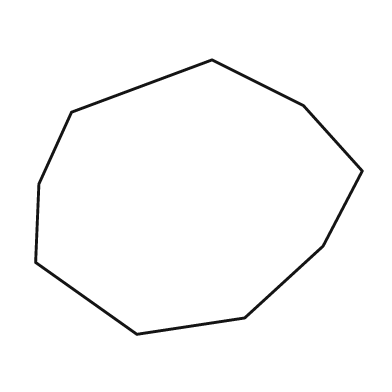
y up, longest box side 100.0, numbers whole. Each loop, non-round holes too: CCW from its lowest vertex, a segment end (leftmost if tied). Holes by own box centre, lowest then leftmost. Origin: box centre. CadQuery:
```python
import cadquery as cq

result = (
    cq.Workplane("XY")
    .moveTo(-19.0, -42.0)
    .lineTo(14.0, -37.0)
    .lineTo(38.0, -15.0)
    .lineTo(50.0, 8.0)
    .lineTo(32.0, 28.0)
    .lineTo(4.0, 42.0)
    .lineTo(-39.0, 26.0)
    .lineTo(-49.0, 4.0)
    .lineTo(-50.0, -20.0)
    .close()
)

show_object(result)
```